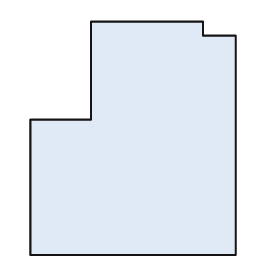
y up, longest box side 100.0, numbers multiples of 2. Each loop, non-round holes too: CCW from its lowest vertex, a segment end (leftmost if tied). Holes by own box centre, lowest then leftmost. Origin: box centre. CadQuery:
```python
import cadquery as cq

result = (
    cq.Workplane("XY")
    .moveTo(-44.0, -50.0)
    .lineTo(44.0, -50.0)
    .lineTo(44.0, 44.0)
    .lineTo(30.0, 44.0)
    .lineTo(30.0, 50.0)
    .lineTo(-18.0, 50.0)
    .lineTo(-18.0, 8.0)
    .lineTo(-44.0, 8.0)
    .close()
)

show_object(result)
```